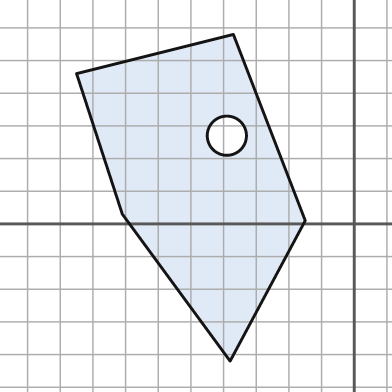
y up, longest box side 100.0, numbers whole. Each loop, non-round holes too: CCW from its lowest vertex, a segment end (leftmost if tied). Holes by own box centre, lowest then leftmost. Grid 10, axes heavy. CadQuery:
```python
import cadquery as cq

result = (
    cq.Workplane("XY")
    .moveTo(-38.0, -42.0)
    .lineTo(-15.0, 1.0)
    .lineTo(-37.0, 58.0)
    .lineTo(-85.0, 46.0)
    .lineTo(-71.0, 3.0)
    .close()
    .moveTo(-39.0, 27.0)
    .circle(6.0)
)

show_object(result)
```